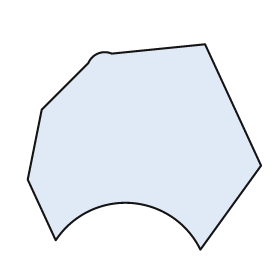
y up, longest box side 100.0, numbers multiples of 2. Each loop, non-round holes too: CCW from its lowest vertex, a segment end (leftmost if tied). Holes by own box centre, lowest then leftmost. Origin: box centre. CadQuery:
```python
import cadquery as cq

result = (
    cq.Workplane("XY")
    .moveTo(24.0, -44.0)
    .lineTo(50.0, -8.0)
    .lineTo(26.0, 44.0)
    .lineTo(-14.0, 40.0)
    .threePointArc((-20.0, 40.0), (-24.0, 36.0))
    .lineTo(-44.0, 16.0)
    .lineTo(-50.0, -14.0)
    .lineTo(-38.0, -40.0)
    .threePointArc((-6.0, -24.0), (24.0, -44.0))
    .close()
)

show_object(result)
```